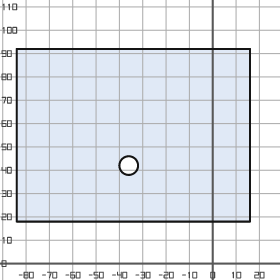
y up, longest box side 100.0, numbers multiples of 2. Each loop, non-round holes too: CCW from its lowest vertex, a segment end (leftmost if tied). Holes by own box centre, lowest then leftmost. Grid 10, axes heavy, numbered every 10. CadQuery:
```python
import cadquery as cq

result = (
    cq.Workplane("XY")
    .moveTo(-84.0, 18.0)
    .lineTo(16.0, 18.0)
    .lineTo(16.0, 92.0)
    .lineTo(-84.0, 92.0)
    .close()
    .moveTo(-36.0, 42.0)
    .circle(4.0)
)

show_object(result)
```